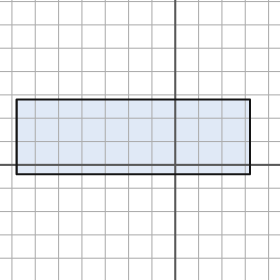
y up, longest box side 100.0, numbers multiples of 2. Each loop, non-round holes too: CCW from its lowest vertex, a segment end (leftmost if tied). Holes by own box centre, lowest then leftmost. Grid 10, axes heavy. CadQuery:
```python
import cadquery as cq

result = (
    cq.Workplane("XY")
    .moveTo(-68.0, -4.0)
    .lineTo(32.0, -4.0)
    .lineTo(32.0, 28.0)
    .lineTo(-68.0, 28.0)
    .close()
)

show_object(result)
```